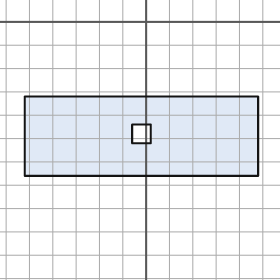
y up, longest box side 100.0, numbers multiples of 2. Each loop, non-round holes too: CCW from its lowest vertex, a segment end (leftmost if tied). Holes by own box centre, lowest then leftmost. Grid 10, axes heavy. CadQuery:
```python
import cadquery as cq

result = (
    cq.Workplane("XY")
    .moveTo(-52.0, -66.0)
    .lineTo(48.0, -66.0)
    .lineTo(48.0, -32.0)
    .lineTo(-52.0, -32.0)
    .close()
    .moveTo(-6.0, -52.0)
    .lineTo(2.0, -52.0)
    .lineTo(2.0, -44.0)
    .lineTo(-6.0, -44.0)
    .close()
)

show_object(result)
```